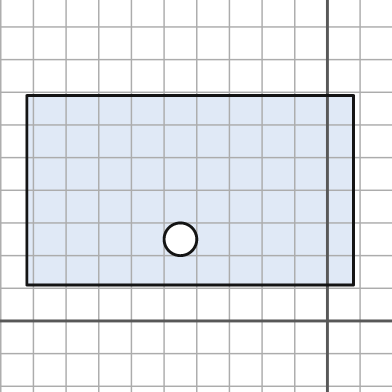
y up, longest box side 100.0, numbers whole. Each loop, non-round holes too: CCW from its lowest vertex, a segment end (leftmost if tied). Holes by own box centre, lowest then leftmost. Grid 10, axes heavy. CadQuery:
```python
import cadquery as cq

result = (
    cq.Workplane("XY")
    .moveTo(-92.0, 11.0)
    .lineTo(8.0, 11.0)
    .lineTo(8.0, 69.0)
    .lineTo(-92.0, 69.0)
    .close()
    .moveTo(-45.0, 25.0)
    .circle(5.0)
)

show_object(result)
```